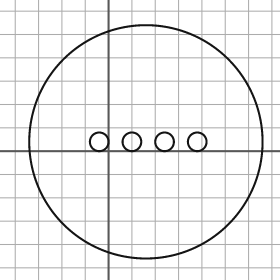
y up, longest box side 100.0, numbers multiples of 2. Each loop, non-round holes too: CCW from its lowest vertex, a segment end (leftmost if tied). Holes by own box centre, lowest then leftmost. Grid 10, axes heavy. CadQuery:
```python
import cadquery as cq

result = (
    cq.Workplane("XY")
    .moveTo(16.0, 4.0)
    .circle(50.0)
    .moveTo(-4.0, 4.0)
    .circle(4.0)
    .moveTo(10.0, 4.0)
    .circle(4.0)
    .moveTo(24.0, 4.0)
    .circle(4.0)
    .moveTo(38.0, 4.0)
    .circle(4.0)
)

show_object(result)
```